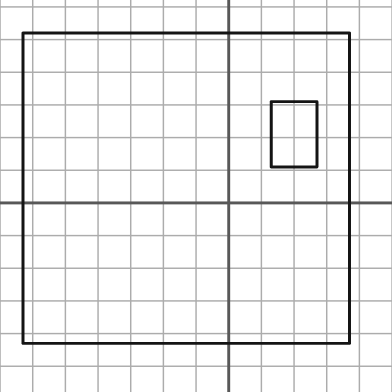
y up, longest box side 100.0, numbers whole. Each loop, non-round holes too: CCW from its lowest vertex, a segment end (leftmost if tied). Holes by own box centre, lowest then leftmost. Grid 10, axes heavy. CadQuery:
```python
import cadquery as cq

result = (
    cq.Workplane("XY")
    .moveTo(-63.0, -43.0)
    .lineTo(37.0, -43.0)
    .lineTo(37.0, 52.0)
    .lineTo(-63.0, 52.0)
    .close()
    .moveTo(13.0, 11.0)
    .lineTo(27.0, 11.0)
    .lineTo(27.0, 31.0)
    .lineTo(13.0, 31.0)
    .close()
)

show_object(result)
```